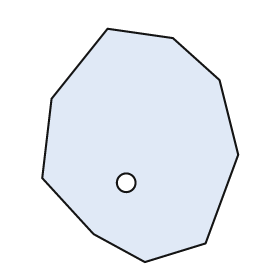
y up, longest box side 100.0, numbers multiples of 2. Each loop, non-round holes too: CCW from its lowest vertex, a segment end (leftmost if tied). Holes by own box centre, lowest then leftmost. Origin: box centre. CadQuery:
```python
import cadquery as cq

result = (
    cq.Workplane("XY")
    .moveTo(2.0, -50.0)
    .lineTo(28.0, -42.0)
    .lineTo(42.0, -4.0)
    .lineTo(34.0, 28.0)
    .lineTo(14.0, 46.0)
    .lineTo(-14.0, 50.0)
    .lineTo(-38.0, 20.0)
    .lineTo(-42.0, -14.0)
    .lineTo(-20.0, -38.0)
    .close()
    .moveTo(-6.0, -16.0)
    .circle(4.0)
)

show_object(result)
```